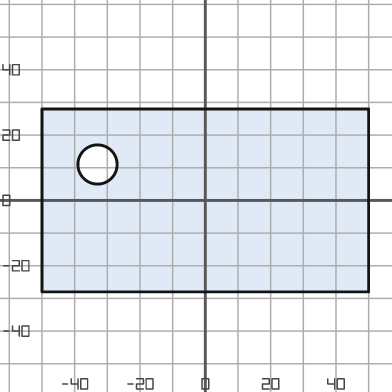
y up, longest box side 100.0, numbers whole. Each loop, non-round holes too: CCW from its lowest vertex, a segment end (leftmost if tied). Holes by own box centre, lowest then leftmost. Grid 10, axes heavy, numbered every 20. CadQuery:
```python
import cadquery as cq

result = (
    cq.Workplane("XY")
    .moveTo(-50.0, -28.0)
    .lineTo(50.0, -28.0)
    .lineTo(50.0, 28.0)
    .lineTo(-50.0, 28.0)
    .close()
    .moveTo(-33.0, 11.0)
    .circle(6.0)
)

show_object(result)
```